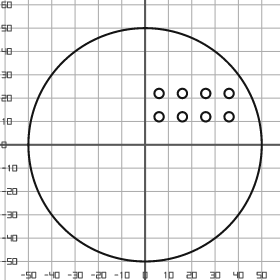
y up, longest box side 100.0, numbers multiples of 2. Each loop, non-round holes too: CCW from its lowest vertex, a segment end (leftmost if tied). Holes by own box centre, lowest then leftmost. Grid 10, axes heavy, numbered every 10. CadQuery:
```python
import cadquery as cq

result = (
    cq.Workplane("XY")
    .moveTo(0.0, 0.0)
    .circle(50.0)
    .moveTo(6.0, 12.0)
    .circle(2.0)
    .moveTo(16.0, 12.0)
    .circle(2.0)
    .moveTo(26.0, 12.0)
    .circle(2.0)
    .moveTo(36.0, 12.0)
    .circle(2.0)
    .moveTo(6.0, 22.0)
    .circle(2.0)
    .moveTo(16.0, 22.0)
    .circle(2.0)
    .moveTo(26.0, 22.0)
    .circle(2.0)
    .moveTo(36.0, 22.0)
    .circle(2.0)
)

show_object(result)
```